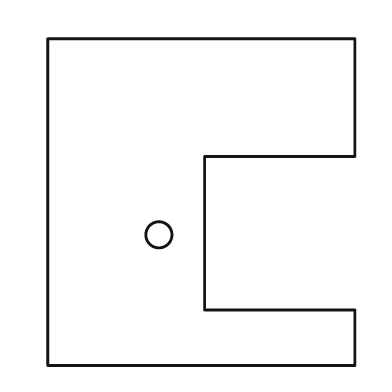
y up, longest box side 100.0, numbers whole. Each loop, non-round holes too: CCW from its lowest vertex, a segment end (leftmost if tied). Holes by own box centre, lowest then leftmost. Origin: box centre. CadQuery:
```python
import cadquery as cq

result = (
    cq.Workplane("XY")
    .moveTo(-47.0, -50.0)
    .lineTo(47.0, -50.0)
    .lineTo(47.0, -33.0)
    .lineTo(1.0, -33.0)
    .lineTo(1.0, 14.0)
    .lineTo(47.0, 14.0)
    .lineTo(47.0, 50.0)
    .lineTo(-47.0, 50.0)
    .close()
    .moveTo(-13.0, -10.0)
    .circle(4.0)
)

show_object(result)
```